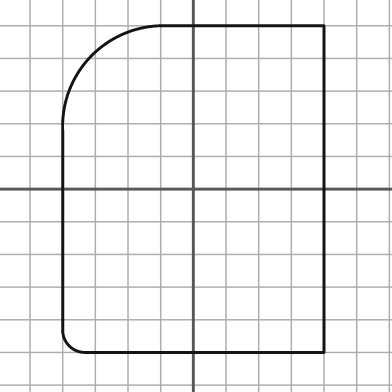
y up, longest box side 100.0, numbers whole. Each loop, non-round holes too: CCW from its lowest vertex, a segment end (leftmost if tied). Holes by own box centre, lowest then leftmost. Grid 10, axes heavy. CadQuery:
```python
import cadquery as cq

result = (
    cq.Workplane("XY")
    .moveTo(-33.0, -50.0)
    .lineTo(40.0, -50.0)
    .lineTo(40.0, 50.0)
    .lineTo(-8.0, 50.0)
    .threePointArc((-31.0, 41.0), (-40.0, 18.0))
    .lineTo(-40.0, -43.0)
    .threePointArc((-38.0, -48.0), (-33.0, -50.0))
    .close()
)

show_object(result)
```